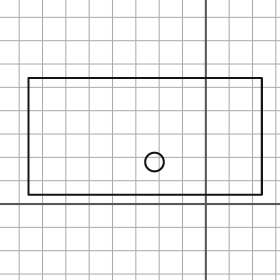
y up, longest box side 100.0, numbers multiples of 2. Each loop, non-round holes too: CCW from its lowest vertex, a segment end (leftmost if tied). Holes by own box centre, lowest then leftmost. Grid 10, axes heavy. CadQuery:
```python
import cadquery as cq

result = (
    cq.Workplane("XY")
    .moveTo(-76.0, 4.0)
    .lineTo(24.0, 4.0)
    .lineTo(24.0, 54.0)
    .lineTo(-76.0, 54.0)
    .close()
    .moveTo(-22.0, 18.0)
    .circle(4.0)
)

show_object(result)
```